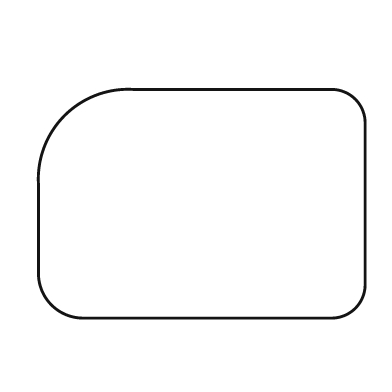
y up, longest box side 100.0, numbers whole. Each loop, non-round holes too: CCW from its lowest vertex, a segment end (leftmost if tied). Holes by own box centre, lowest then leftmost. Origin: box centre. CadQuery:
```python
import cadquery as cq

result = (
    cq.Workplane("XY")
    .moveTo(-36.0, -35.0)
    .lineTo(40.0, -35.0)
    .threePointArc((47.0, -32.0), (50.0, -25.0))
    .lineTo(50.0, 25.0)
    .threePointArc((47.0, 32.0), (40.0, 35.0))
    .lineTo(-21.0, 35.0)
    .threePointArc((-42.0, 27.0), (-50.0, 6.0))
    .lineTo(-50.0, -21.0)
    .threePointArc((-46.0, -31.0), (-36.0, -35.0))
    .close()
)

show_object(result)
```